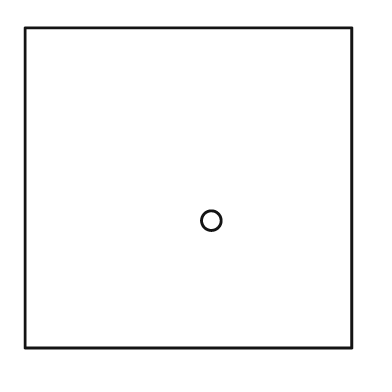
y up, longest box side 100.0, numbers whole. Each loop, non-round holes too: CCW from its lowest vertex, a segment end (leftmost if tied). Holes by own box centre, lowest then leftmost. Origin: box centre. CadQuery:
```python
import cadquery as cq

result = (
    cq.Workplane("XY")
    .moveTo(-50.0, -49.0)
    .lineTo(50.0, -49.0)
    .lineTo(50.0, 49.0)
    .lineTo(-50.0, 49.0)
    .close()
    .moveTo(7.0, -10.0)
    .circle(3.0)
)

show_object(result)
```